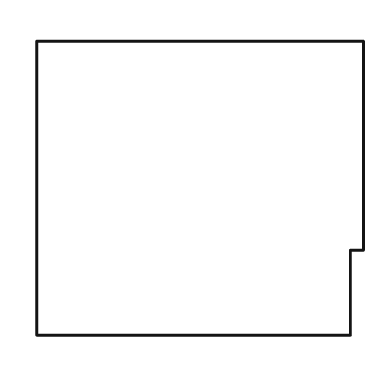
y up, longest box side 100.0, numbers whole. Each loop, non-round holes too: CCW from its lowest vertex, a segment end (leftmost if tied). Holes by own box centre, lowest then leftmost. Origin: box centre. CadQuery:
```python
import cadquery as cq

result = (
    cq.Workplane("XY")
    .moveTo(-50.0, -45.0)
    .lineTo(46.0, -45.0)
    .lineTo(46.0, -19.0)
    .lineTo(50.0, -19.0)
    .lineTo(50.0, 45.0)
    .lineTo(-50.0, 45.0)
    .close()
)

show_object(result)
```